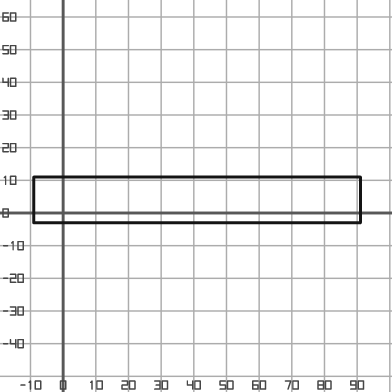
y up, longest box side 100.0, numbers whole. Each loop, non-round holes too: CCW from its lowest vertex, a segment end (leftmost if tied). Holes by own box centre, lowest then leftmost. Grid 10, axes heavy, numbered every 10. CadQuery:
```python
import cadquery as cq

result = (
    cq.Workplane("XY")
    .moveTo(-9.0, -3.0)
    .lineTo(91.0, -3.0)
    .lineTo(91.0, 11.0)
    .lineTo(-9.0, 11.0)
    .close()
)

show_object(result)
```